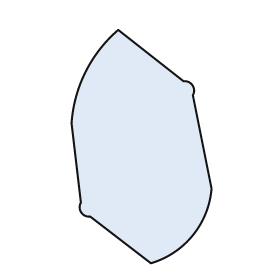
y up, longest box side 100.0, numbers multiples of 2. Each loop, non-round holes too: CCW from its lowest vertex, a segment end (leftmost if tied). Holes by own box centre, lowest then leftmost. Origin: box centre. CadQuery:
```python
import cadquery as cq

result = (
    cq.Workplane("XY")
    .moveTo(4.0, -50.0)
    .threePointArc((22.0, -38.0), (30.0, -18.0))
    .lineTo(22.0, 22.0)
    .threePointArc((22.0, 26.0), (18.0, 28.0))
    .lineTo(-10.0, 50.0)
    .threePointArc((-24.0, 32.0), (-30.0, 10.0))
    .lineTo(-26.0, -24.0)
    .threePointArc((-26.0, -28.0), (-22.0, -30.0))
    .close()
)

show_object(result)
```